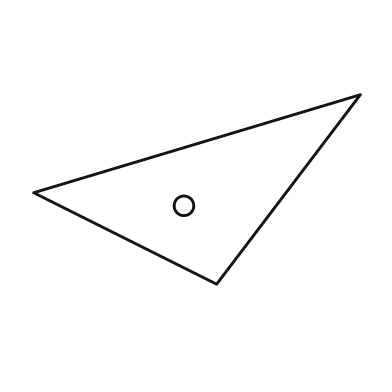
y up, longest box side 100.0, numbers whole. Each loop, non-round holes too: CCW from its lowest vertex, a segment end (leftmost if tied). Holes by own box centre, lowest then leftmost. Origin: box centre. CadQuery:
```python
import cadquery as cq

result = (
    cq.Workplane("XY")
    .moveTo(6.0, -29.0)
    .lineTo(50.0, 29.0)
    .lineTo(-50.0, -1.0)
    .close()
    .moveTo(-4.0, -5.0)
    .circle(3.0)
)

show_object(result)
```